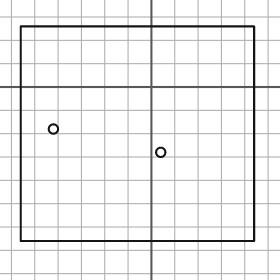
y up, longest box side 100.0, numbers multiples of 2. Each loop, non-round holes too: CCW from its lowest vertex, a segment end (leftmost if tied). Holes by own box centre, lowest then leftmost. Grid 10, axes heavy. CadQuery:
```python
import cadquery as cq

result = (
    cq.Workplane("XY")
    .moveTo(-56.0, -66.0)
    .lineTo(44.0, -66.0)
    .lineTo(44.0, 26.0)
    .lineTo(-56.0, 26.0)
    .close()
    .moveTo(4.0, -28.0)
    .circle(2.0)
    .moveTo(-42.0, -18.0)
    .circle(2.0)
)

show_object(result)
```